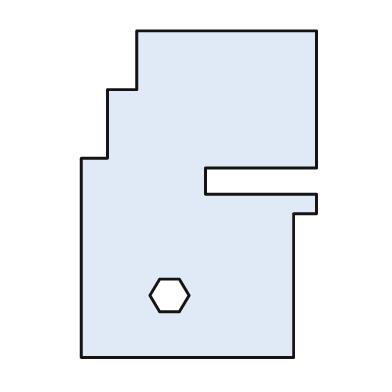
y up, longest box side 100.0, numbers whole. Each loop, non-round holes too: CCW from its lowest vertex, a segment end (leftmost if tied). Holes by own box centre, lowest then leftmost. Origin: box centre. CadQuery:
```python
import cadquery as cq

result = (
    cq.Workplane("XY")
    .moveTo(-36.0, -50.0)
    .lineTo(29.0, -50.0)
    .lineTo(29.0, -6.0)
    .lineTo(36.0, -6.0)
    .lineTo(36.0, 0.0)
    .lineTo(2.0, 0.0)
    .lineTo(2.0, 8.0)
    .lineTo(36.0, 8.0)
    .lineTo(36.0, 50.0)
    .lineTo(-19.0, 50.0)
    .lineTo(-19.0, 32.0)
    .lineTo(-28.0, 32.0)
    .lineTo(-28.0, 11.0)
    .lineTo(-36.0, 11.0)
    .close()
    .moveTo(-12.0, -36.0)
    .lineTo(-6.0, -36.0)
    .lineTo(-3.0, -31.0)
    .lineTo(-6.0, -26.0)
    .lineTo(-12.0, -26.0)
    .lineTo(-15.0, -31.0)
    .close()
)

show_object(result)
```